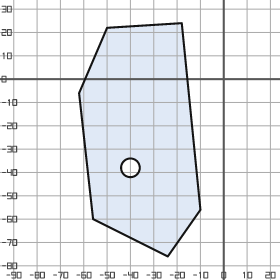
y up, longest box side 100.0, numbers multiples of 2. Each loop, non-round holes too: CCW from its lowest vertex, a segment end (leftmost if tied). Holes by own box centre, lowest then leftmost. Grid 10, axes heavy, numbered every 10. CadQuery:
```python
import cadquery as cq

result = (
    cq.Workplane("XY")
    .moveTo(-24.0, -76.0)
    .lineTo(-10.0, -56.0)
    .lineTo(-18.0, 24.0)
    .lineTo(-50.0, 22.0)
    .lineTo(-62.0, -6.0)
    .lineTo(-56.0, -60.0)
    .close()
    .moveTo(-40.0, -38.0)
    .circle(4.0)
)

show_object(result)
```